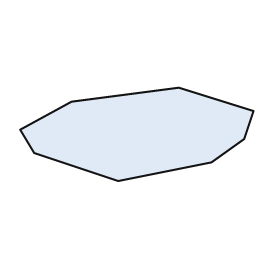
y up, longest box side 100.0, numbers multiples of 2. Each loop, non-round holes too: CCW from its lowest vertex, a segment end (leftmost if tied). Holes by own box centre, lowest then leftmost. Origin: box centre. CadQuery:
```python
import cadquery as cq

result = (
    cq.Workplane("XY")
    .moveTo(-8.0, -20.0)
    .lineTo(32.0, -12.0)
    .lineTo(46.0, -2.0)
    .lineTo(50.0, 10.0)
    .lineTo(18.0, 20.0)
    .lineTo(-28.0, 14.0)
    .lineTo(-50.0, 2.0)
    .lineTo(-44.0, -8.0)
    .close()
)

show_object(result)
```